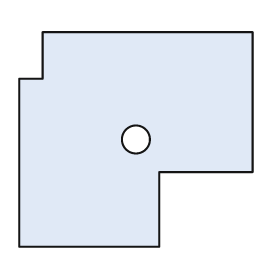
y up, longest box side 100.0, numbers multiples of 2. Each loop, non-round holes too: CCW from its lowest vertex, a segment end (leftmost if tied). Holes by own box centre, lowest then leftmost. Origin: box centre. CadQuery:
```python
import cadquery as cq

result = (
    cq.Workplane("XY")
    .moveTo(-50.0, -46.0)
    .lineTo(10.0, -46.0)
    .lineTo(10.0, -14.0)
    .lineTo(50.0, -14.0)
    .lineTo(50.0, 46.0)
    .lineTo(-40.0, 46.0)
    .lineTo(-40.0, 26.0)
    .lineTo(-50.0, 26.0)
    .close()
    .moveTo(0.0, 0.0)
    .circle(6.0)
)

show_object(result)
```